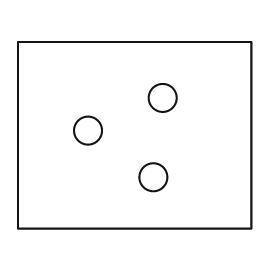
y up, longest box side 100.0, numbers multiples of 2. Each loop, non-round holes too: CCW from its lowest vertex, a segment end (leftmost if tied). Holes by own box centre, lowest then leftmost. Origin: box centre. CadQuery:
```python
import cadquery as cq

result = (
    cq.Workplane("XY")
    .moveTo(-50.0, -40.0)
    .lineTo(50.0, -40.0)
    .lineTo(50.0, 40.0)
    .lineTo(-50.0, 40.0)
    .close()
    .moveTo(8.0, -18.0)
    .circle(6.0)
    .moveTo(-20.0, 2.0)
    .circle(6.0)
    .moveTo(12.0, 16.0)
    .circle(6.0)
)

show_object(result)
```